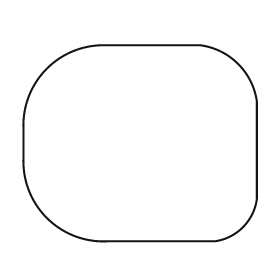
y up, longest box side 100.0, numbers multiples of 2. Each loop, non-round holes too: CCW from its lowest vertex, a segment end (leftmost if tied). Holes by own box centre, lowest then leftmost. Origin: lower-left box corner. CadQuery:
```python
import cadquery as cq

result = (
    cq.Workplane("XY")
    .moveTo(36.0, 0.0)
    .lineTo(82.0, 0.0)
    .threePointArc((94.0, 6.0), (100.0, 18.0))
    .lineTo(100.0, 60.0)
    .threePointArc((92.0, 76.0), (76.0, 84.0))
    .lineTo(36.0, 84.0)
    .threePointArc((10.0, 74.0), (0.0, 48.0))
    .lineTo(0.0, 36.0)
    .threePointArc((10.0, 10.0), (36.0, 0.0))
    .close()
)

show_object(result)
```